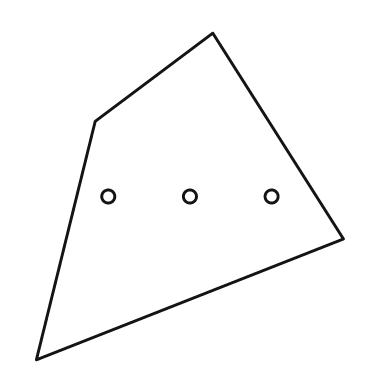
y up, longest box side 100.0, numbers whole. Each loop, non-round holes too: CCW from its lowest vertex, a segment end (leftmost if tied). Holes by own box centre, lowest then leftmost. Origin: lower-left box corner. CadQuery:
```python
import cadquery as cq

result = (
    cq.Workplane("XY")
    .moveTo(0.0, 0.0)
    .lineTo(94.0, 37.0)
    .lineTo(54.0, 100.0)
    .lineTo(18.0, 73.0)
    .close()
    .moveTo(22.0, 50.0)
    .circle(2.0)
    .moveTo(47.0, 50.0)
    .circle(2.0)
    .moveTo(72.0, 50.0)
    .circle(2.0)
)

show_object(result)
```